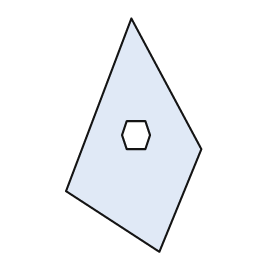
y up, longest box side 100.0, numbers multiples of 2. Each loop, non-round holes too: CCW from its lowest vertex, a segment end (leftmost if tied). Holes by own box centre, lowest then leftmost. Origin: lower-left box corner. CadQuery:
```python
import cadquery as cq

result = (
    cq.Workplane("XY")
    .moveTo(40.0, 0.0)
    .lineTo(58.0, 44.0)
    .lineTo(28.0, 100.0)
    .lineTo(0.0, 26.0)
    .close()
    .moveTo(26.0, 44.0)
    .lineTo(34.0, 44.0)
    .lineTo(36.0, 50.0)
    .lineTo(34.0, 56.0)
    .lineTo(26.0, 56.0)
    .lineTo(24.0, 50.0)
    .close()
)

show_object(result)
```